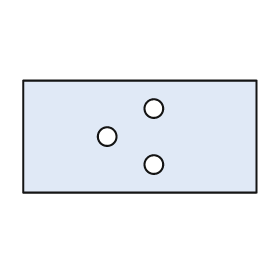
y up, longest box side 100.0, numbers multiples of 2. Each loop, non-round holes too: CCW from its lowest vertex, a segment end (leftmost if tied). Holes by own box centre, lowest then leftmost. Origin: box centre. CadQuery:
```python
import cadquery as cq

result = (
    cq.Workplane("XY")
    .moveTo(-50.0, -24.0)
    .lineTo(50.0, -24.0)
    .lineTo(50.0, 24.0)
    .lineTo(-50.0, 24.0)
    .close()
    .moveTo(6.0, -12.0)
    .circle(4.0)
    .moveTo(-14.0, 0.0)
    .circle(4.0)
    .moveTo(6.0, 12.0)
    .circle(4.0)
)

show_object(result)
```